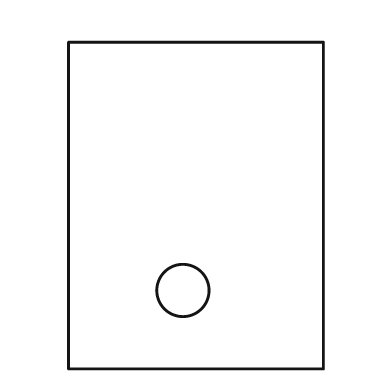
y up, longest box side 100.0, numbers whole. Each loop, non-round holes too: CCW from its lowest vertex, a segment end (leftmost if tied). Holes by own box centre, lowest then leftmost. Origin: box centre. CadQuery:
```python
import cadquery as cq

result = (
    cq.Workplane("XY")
    .moveTo(-39.0, -50.0)
    .lineTo(39.0, -50.0)
    .lineTo(39.0, 50.0)
    .lineTo(-39.0, 50.0)
    .close()
    .moveTo(-4.0, -26.0)
    .circle(8.0)
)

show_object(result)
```